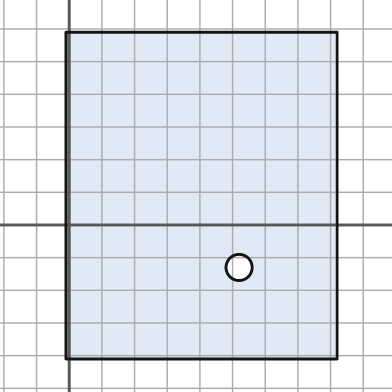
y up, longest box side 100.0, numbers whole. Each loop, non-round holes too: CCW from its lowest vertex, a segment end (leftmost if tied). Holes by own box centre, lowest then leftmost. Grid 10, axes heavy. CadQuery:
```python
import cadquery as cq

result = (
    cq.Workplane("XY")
    .moveTo(-1.0, -41.0)
    .lineTo(82.0, -41.0)
    .lineTo(82.0, 59.0)
    .lineTo(-1.0, 59.0)
    .close()
    .moveTo(52.0, -13.0)
    .circle(4.0)
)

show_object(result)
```